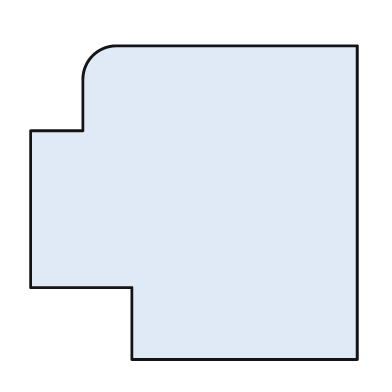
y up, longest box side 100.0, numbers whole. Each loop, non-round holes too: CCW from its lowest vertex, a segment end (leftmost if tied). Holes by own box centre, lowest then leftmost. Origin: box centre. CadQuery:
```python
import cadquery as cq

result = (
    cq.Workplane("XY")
    .moveTo(-19.0, -48.0)
    .lineTo(50.0, -48.0)
    .lineTo(50.0, 48.0)
    .lineTo(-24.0, 48.0)
    .threePointArc((-31.0, 45.0), (-34.0, 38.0))
    .lineTo(-34.0, 22.0)
    .lineTo(-50.0, 22.0)
    .lineTo(-50.0, -26.0)
    .lineTo(-19.0, -26.0)
    .close()
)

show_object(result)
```